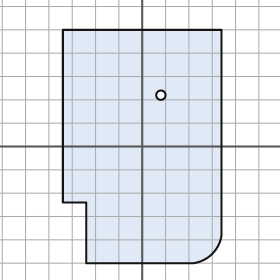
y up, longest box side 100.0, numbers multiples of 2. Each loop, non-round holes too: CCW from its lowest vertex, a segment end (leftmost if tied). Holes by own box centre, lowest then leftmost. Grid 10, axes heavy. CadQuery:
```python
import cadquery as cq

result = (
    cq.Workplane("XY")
    .moveTo(-24.0, -50.0)
    .lineTo(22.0, -50.0)
    .threePointArc((30.0, -46.0), (34.0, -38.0))
    .lineTo(34.0, 50.0)
    .lineTo(-34.0, 50.0)
    .lineTo(-34.0, -24.0)
    .lineTo(-24.0, -24.0)
    .close()
    .moveTo(8.0, 22.0)
    .circle(2.0)
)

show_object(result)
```